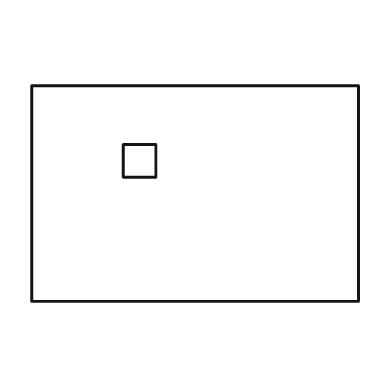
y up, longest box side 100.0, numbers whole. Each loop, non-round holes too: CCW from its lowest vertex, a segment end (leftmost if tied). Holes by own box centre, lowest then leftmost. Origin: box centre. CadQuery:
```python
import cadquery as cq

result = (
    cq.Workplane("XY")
    .moveTo(-50.0, -33.0)
    .lineTo(50.0, -33.0)
    .lineTo(50.0, 33.0)
    .lineTo(-50.0, 33.0)
    .close()
    .moveTo(-22.0, 5.0)
    .lineTo(-12.0, 5.0)
    .lineTo(-12.0, 15.0)
    .lineTo(-22.0, 15.0)
    .close()
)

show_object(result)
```